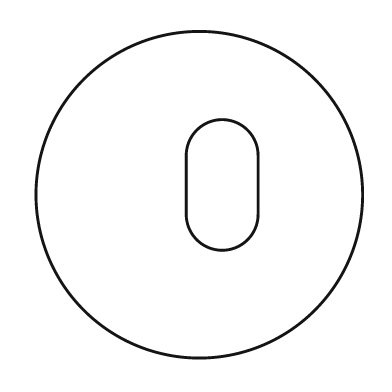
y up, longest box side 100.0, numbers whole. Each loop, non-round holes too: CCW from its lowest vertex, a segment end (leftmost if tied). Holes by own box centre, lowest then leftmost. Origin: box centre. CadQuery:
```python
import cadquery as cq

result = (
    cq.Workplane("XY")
    .moveTo(0.0, 0.0)
    .circle(50.0)
    .moveTo(-4.0, -6.0)
    .threePointArc((7.0, -17.0), (18.0, -6.0))
    .lineTo(18.0, 12.0)
    .threePointArc((7.0, 23.0), (-4.0, 12.0))
    .close()
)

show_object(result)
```